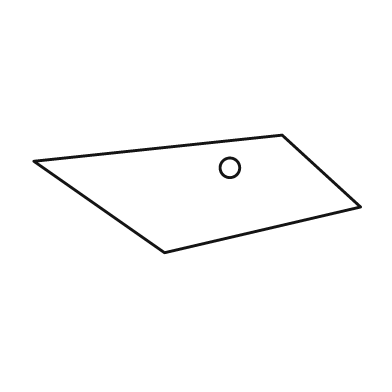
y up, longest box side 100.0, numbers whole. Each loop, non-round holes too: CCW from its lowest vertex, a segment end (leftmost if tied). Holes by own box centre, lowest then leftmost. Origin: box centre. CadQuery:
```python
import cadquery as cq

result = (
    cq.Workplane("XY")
    .moveTo(-10.0, -18.0)
    .lineTo(50.0, -4.0)
    .lineTo(26.0, 18.0)
    .lineTo(-50.0, 10.0)
    .close()
    .moveTo(10.0, 8.0)
    .circle(3.0)
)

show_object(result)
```